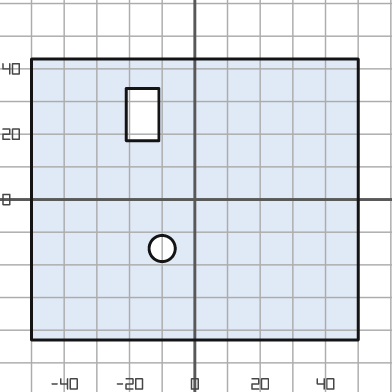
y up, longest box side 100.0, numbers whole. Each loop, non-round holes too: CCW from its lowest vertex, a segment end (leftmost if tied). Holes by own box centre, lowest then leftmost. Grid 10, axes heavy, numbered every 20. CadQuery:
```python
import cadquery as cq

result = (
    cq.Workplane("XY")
    .moveTo(-50.0, -43.0)
    .lineTo(50.0, -43.0)
    .lineTo(50.0, 43.0)
    .lineTo(-50.0, 43.0)
    .close()
    .moveTo(-10.0, -15.0)
    .circle(4.0)
    .moveTo(-21.0, 18.0)
    .lineTo(-11.0, 18.0)
    .lineTo(-11.0, 34.0)
    .lineTo(-21.0, 34.0)
    .close()
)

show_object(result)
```